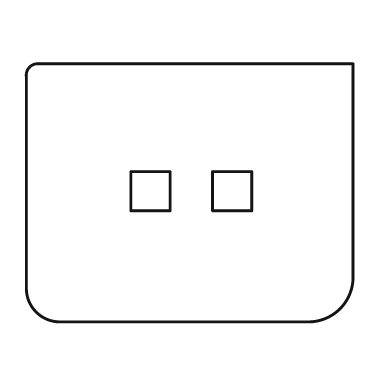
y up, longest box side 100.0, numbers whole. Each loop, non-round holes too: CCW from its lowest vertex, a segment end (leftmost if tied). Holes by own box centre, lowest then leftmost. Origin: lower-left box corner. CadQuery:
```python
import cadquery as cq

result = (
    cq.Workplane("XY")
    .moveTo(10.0, 0.0)
    .lineTo(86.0, 0.0)
    .threePointArc((96.0, 4.0), (100.0, 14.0))
    .lineTo(100.0, 79.0)
    .lineTo(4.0, 79.0)
    .threePointArc((1.0, 78.0), (0.0, 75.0))
    .lineTo(0.0, 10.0)
    .threePointArc((3.0, 3.0), (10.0, 0.0))
    .close()
    .moveTo(32.0, 34.0)
    .lineTo(44.0, 34.0)
    .lineTo(44.0, 46.0)
    .lineTo(32.0, 46.0)
    .close()
    .moveTo(57.0, 34.0)
    .lineTo(69.0, 34.0)
    .lineTo(69.0, 46.0)
    .lineTo(57.0, 46.0)
    .close()
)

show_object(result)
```